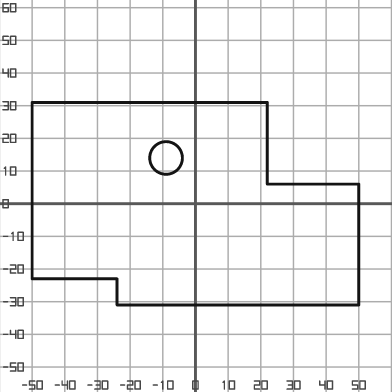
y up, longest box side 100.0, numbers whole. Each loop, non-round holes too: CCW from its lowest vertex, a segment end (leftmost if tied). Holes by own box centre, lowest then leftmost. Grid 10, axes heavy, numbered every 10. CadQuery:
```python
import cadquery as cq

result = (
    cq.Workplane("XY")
    .moveTo(-24.0, -31.0)
    .lineTo(50.0, -31.0)
    .lineTo(50.0, 6.0)
    .lineTo(22.0, 6.0)
    .lineTo(22.0, 31.0)
    .lineTo(-50.0, 31.0)
    .lineTo(-50.0, -23.0)
    .lineTo(-24.0, -23.0)
    .close()
    .moveTo(-9.0, 14.0)
    .circle(5.0)
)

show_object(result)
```